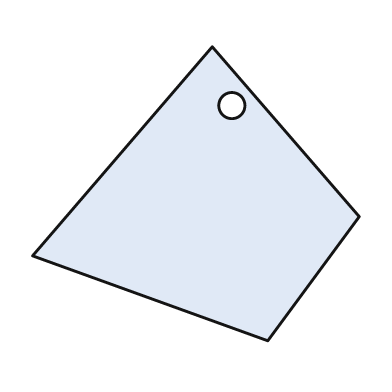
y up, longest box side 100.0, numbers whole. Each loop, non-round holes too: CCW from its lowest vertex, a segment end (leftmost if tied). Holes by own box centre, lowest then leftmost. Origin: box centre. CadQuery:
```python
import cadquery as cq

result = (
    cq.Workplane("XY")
    .moveTo(22.0, -45.0)
    .lineTo(50.0, -7.0)
    .lineTo(5.0, 45.0)
    .lineTo(-50.0, -19.0)
    .close()
    .moveTo(11.0, 27.0)
    .circle(4.0)
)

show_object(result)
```